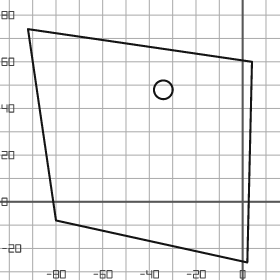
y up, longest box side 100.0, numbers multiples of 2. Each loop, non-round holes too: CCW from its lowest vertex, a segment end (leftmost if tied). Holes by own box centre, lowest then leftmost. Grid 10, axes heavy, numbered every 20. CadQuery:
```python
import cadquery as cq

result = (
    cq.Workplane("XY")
    .moveTo(2.0, -26.0)
    .lineTo(4.0, 60.0)
    .lineTo(-92.0, 74.0)
    .lineTo(-80.0, -8.0)
    .close()
    .moveTo(-34.0, 48.0)
    .circle(4.0)
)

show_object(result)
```